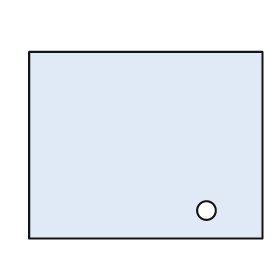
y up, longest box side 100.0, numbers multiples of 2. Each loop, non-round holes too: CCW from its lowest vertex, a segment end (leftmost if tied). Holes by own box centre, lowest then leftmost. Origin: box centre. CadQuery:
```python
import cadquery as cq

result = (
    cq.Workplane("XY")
    .moveTo(-50.0, -40.0)
    .lineTo(50.0, -40.0)
    .lineTo(50.0, 40.0)
    .lineTo(-50.0, 40.0)
    .close()
    .moveTo(26.0, -28.0)
    .circle(4.0)
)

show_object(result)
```